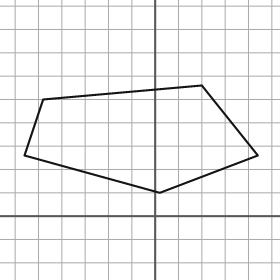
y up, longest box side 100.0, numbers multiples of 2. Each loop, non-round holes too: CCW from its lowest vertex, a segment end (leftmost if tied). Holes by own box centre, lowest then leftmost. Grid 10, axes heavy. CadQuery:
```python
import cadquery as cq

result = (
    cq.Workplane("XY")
    .moveTo(2.0, 10.0)
    .lineTo(44.0, 26.0)
    .lineTo(20.0, 56.0)
    .lineTo(-48.0, 50.0)
    .lineTo(-56.0, 26.0)
    .close()
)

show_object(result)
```